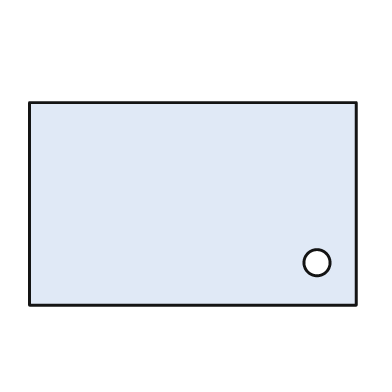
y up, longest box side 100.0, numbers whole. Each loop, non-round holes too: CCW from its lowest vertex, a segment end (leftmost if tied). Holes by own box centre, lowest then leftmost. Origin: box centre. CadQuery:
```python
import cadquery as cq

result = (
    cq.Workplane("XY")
    .moveTo(-50.0, -31.0)
    .lineTo(50.0, -31.0)
    .lineTo(50.0, 31.0)
    .lineTo(-50.0, 31.0)
    .close()
    .moveTo(38.0, -18.0)
    .circle(4.0)
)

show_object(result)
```